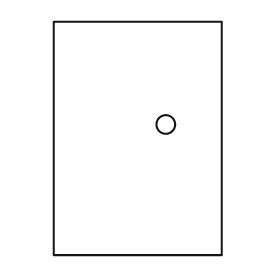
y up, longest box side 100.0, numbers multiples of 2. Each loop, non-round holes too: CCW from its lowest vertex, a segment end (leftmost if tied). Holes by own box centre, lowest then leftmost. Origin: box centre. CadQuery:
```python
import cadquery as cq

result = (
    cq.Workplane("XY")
    .moveTo(-36.0, -50.0)
    .lineTo(36.0, -50.0)
    .lineTo(36.0, 50.0)
    .lineTo(-36.0, 50.0)
    .close()
    .moveTo(12.0, 6.0)
    .circle(4.0)
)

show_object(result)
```